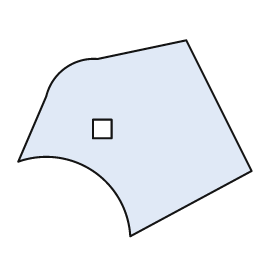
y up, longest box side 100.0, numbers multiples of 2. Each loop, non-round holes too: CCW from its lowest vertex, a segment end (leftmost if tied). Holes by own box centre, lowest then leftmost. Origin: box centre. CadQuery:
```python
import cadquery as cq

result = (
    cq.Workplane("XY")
    .moveTo(-2.0, -42.0)
    .lineTo(50.0, -14.0)
    .lineTo(22.0, 42.0)
    .lineTo(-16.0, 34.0)
    .threePointArc((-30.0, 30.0), (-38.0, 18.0))
    .lineTo(-50.0, -10.0)
    .threePointArc((-18.0, -14.0), (-2.0, -42.0))
    .close()
    .moveTo(-18.0, 0.0)
    .lineTo(-10.0, 0.0)
    .lineTo(-10.0, 8.0)
    .lineTo(-18.0, 8.0)
    .close()
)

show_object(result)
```